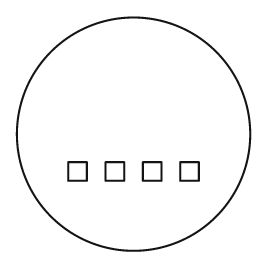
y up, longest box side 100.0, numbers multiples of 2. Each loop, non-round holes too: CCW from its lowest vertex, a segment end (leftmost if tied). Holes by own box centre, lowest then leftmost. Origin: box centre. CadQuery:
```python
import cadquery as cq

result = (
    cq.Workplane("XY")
    .moveTo(0.0, 0.0)
    .circle(50.0)
    .moveTo(-28.0, -20.0)
    .lineTo(-20.0, -20.0)
    .lineTo(-20.0, -12.0)
    .lineTo(-28.0, -12.0)
    .close()
    .moveTo(-12.0, -20.0)
    .lineTo(-4.0, -20.0)
    .lineTo(-4.0, -12.0)
    .lineTo(-12.0, -12.0)
    .close()
    .moveTo(4.0, -20.0)
    .lineTo(12.0, -20.0)
    .lineTo(12.0, -12.0)
    .lineTo(4.0, -12.0)
    .close()
    .moveTo(20.0, -20.0)
    .lineTo(28.0, -20.0)
    .lineTo(28.0, -12.0)
    .lineTo(20.0, -12.0)
    .close()
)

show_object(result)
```